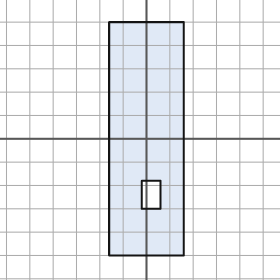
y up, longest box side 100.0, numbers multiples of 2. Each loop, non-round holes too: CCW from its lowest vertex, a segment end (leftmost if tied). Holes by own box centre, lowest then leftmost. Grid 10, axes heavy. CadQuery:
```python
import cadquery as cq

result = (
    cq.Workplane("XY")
    .moveTo(-16.0, -50.0)
    .lineTo(16.0, -50.0)
    .lineTo(16.0, 50.0)
    .lineTo(-16.0, 50.0)
    .close()
    .moveTo(-2.0, -30.0)
    .lineTo(6.0, -30.0)
    .lineTo(6.0, -18.0)
    .lineTo(-2.0, -18.0)
    .close()
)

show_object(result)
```